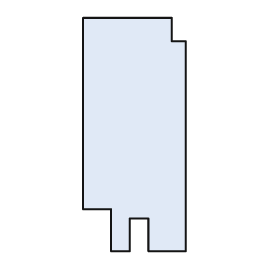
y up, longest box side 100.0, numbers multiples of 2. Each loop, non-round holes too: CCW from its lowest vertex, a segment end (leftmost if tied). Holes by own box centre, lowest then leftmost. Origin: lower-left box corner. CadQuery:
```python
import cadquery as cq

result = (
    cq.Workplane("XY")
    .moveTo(12.0, 0.0)
    .lineTo(20.0, 0.0)
    .lineTo(20.0, 14.0)
    .lineTo(28.0, 14.0)
    .lineTo(28.0, 0.0)
    .lineTo(44.0, 0.0)
    .lineTo(44.0, 90.0)
    .lineTo(38.0, 90.0)
    .lineTo(38.0, 100.0)
    .lineTo(0.0, 100.0)
    .lineTo(0.0, 18.0)
    .lineTo(12.0, 18.0)
    .close()
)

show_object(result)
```